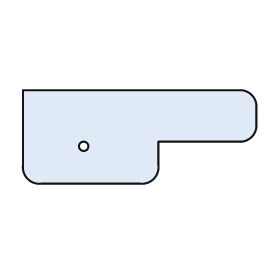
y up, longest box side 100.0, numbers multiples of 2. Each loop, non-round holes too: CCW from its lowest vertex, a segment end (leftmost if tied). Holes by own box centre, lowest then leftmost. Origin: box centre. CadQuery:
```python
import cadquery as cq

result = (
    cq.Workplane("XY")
    .moveTo(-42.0, -20.0)
    .lineTo(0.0, -20.0)
    .threePointArc((6.0, -18.0), (8.0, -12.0))
    .lineTo(8.0, -2.0)
    .lineTo(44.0, -2.0)
    .threePointArc((48.0, 0.0), (50.0, 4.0))
    .lineTo(50.0, 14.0)
    .threePointArc((48.0, 18.0), (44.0, 20.0))
    .lineTo(-50.0, 20.0)
    .lineTo(-50.0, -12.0)
    .threePointArc((-48.0, -18.0), (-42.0, -20.0))
    .close()
    .moveTo(-24.0, -4.0)
    .circle(2.0)
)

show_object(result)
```